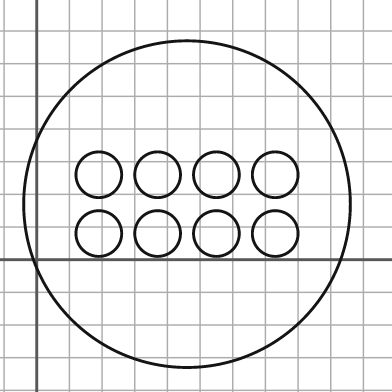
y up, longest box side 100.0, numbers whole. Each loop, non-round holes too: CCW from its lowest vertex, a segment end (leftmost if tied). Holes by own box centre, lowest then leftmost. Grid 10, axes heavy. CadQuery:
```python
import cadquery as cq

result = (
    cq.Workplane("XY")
    .moveTo(46.0, 17.0)
    .circle(50.0)
    .moveTo(19.0, 8.0)
    .circle(7.0)
    .moveTo(37.0, 8.0)
    .circle(7.0)
    .moveTo(55.0, 8.0)
    .circle(7.0)
    .moveTo(73.0, 8.0)
    .circle(7.0)
    .moveTo(19.0, 26.0)
    .circle(7.0)
    .moveTo(37.0, 26.0)
    .circle(7.0)
    .moveTo(55.0, 26.0)
    .circle(7.0)
    .moveTo(73.0, 26.0)
    .circle(7.0)
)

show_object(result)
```